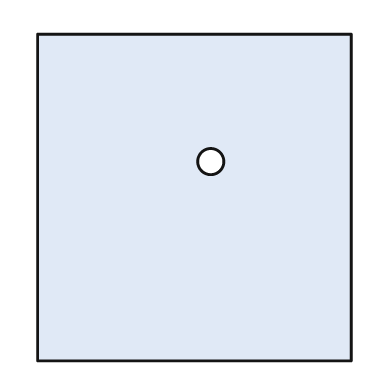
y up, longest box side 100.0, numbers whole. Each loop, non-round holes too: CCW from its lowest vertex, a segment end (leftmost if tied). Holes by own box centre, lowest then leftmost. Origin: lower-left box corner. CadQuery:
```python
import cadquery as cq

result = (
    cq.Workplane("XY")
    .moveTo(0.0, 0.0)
    .lineTo(96.0, 0.0)
    .lineTo(96.0, 100.0)
    .lineTo(0.0, 100.0)
    .close()
    .moveTo(53.0, 61.0)
    .circle(4.0)
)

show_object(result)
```